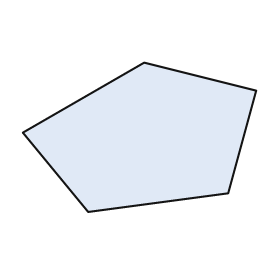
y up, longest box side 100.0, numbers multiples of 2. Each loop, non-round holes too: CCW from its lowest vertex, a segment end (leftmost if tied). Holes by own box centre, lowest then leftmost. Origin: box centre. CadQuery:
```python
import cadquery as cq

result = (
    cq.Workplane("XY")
    .moveTo(-22.0, -32.0)
    .lineTo(38.0, -24.0)
    .lineTo(50.0, 20.0)
    .lineTo(2.0, 32.0)
    .lineTo(-50.0, 2.0)
    .close()
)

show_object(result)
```